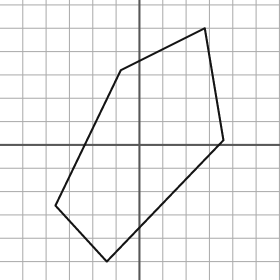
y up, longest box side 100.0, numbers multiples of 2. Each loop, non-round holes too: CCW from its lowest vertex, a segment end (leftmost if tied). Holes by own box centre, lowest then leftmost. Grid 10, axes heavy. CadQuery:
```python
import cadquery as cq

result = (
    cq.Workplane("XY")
    .moveTo(-14.0, -50.0)
    .lineTo(36.0, 2.0)
    .lineTo(28.0, 50.0)
    .lineTo(-8.0, 32.0)
    .lineTo(-36.0, -26.0)
    .close()
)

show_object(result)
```